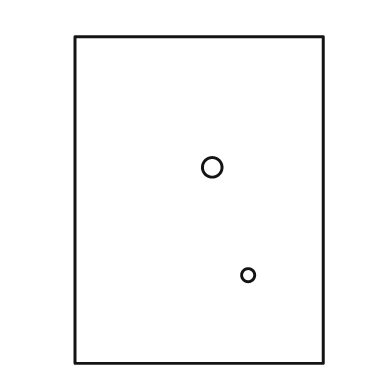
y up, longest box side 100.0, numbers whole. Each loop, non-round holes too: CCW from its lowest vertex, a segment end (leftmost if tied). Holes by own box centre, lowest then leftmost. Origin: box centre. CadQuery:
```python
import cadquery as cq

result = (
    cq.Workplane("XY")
    .moveTo(-38.0, -50.0)
    .lineTo(38.0, -50.0)
    .lineTo(38.0, 50.0)
    .lineTo(-38.0, 50.0)
    .close()
    .moveTo(15.0, -23.0)
    .circle(2.0)
    .moveTo(4.0, 10.0)
    .circle(3.0)
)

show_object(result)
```